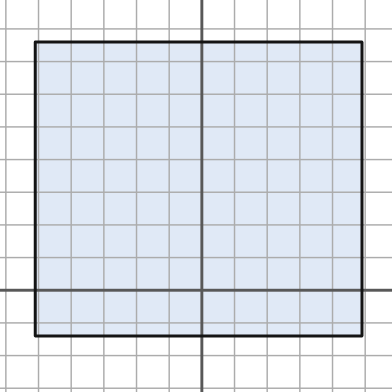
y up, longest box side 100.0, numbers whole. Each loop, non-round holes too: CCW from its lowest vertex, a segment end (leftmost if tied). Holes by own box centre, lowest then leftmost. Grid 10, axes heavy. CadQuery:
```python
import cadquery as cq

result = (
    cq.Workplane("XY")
    .moveTo(-51.0, -14.0)
    .lineTo(49.0, -14.0)
    .lineTo(49.0, 76.0)
    .lineTo(-51.0, 76.0)
    .close()
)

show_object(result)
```